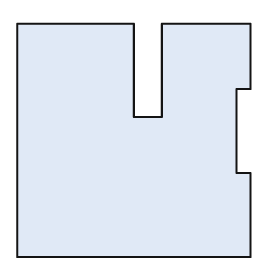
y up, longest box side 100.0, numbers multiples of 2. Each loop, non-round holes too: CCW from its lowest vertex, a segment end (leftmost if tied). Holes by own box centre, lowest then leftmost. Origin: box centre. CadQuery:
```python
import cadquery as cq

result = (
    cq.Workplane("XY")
    .moveTo(-50.0, -50.0)
    .lineTo(50.0, -50.0)
    .lineTo(50.0, -14.0)
    .lineTo(44.0, -14.0)
    .lineTo(44.0, 22.0)
    .lineTo(50.0, 22.0)
    .lineTo(50.0, 50.0)
    .lineTo(12.0, 50.0)
    .lineTo(12.0, 10.0)
    .lineTo(0.0, 10.0)
    .lineTo(0.0, 50.0)
    .lineTo(-50.0, 50.0)
    .close()
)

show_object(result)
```